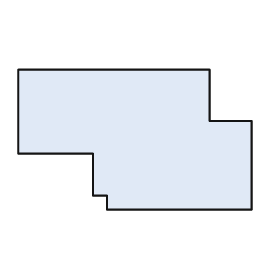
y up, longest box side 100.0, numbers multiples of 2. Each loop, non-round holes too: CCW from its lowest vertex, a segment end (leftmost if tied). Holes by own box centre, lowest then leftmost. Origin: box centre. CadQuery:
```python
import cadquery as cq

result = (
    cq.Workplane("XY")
    .moveTo(-12.0, -30.0)
    .lineTo(50.0, -30.0)
    .lineTo(50.0, 8.0)
    .lineTo(32.0, 8.0)
    .lineTo(32.0, 30.0)
    .lineTo(-50.0, 30.0)
    .lineTo(-50.0, -6.0)
    .lineTo(-18.0, -6.0)
    .lineTo(-18.0, -24.0)
    .lineTo(-12.0, -24.0)
    .close()
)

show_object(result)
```